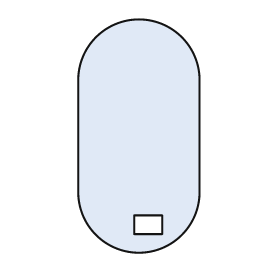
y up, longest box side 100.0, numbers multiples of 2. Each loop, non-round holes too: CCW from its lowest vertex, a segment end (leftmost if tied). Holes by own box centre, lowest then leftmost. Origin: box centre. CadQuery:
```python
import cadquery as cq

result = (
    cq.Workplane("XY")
    .moveTo(-26.0, -24.0)
    .threePointArc((0.0, -50.0), (26.0, -24.0))
    .lineTo(26.0, 24.0)
    .threePointArc((0.0, 50.0), (-26.0, 24.0))
    .close()
    .moveTo(-2.0, -42.0)
    .lineTo(10.0, -42.0)
    .lineTo(10.0, -34.0)
    .lineTo(-2.0, -34.0)
    .close()
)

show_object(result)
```